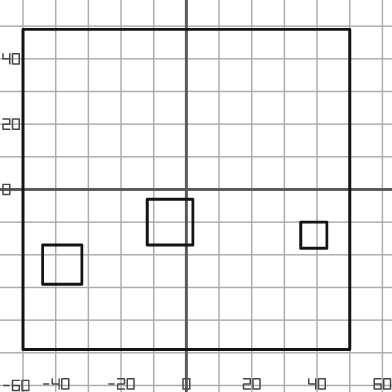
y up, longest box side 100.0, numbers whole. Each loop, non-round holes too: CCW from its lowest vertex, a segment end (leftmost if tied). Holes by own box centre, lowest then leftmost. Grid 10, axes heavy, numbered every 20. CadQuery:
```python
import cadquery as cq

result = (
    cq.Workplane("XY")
    .moveTo(-50.0, -49.0)
    .lineTo(50.0, -49.0)
    .lineTo(50.0, 49.0)
    .lineTo(-50.0, 49.0)
    .close()
    .moveTo(-44.0, -29.0)
    .lineTo(-32.0, -29.0)
    .lineTo(-32.0, -17.0)
    .lineTo(-44.0, -17.0)
    .close()
    .moveTo(35.0, -18.0)
    .lineTo(43.0, -18.0)
    .lineTo(43.0, -10.0)
    .lineTo(35.0, -10.0)
    .close()
    .moveTo(-12.0, -17.0)
    .lineTo(2.0, -17.0)
    .lineTo(2.0, -3.0)
    .lineTo(-12.0, -3.0)
    .close()
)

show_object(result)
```